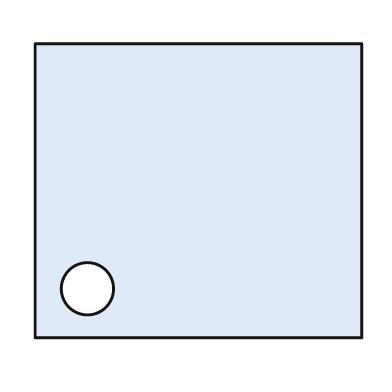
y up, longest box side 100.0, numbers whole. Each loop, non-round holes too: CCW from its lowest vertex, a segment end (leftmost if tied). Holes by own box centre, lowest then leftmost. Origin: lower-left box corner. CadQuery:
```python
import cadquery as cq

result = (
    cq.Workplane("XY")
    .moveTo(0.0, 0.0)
    .lineTo(100.0, 0.0)
    .lineTo(100.0, 90.0)
    .lineTo(0.0, 90.0)
    .close()
    .moveTo(16.0, 15.0)
    .circle(8.0)
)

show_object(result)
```